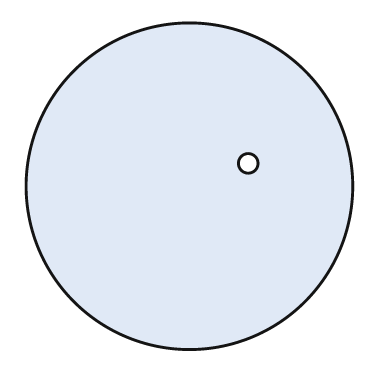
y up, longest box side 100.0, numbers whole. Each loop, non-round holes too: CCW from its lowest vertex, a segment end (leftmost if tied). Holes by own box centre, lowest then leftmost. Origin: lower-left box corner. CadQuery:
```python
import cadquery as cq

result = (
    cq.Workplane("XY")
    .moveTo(50.0, 50.0)
    .circle(50.0)
    .moveTo(68.0, 57.0)
    .circle(3.0)
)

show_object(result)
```